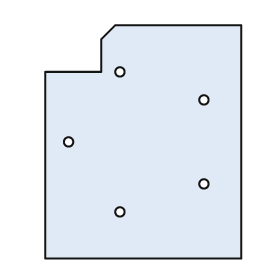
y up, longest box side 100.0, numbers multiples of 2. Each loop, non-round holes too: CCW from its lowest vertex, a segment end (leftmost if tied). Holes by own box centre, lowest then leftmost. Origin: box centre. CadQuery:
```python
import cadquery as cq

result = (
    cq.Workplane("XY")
    .moveTo(-42.0, -50.0)
    .lineTo(42.0, -50.0)
    .lineTo(42.0, 50.0)
    .lineTo(-12.0, 50.0)
    .lineTo(-18.0, 44.0)
    .lineTo(-18.0, 30.0)
    .lineTo(-42.0, 30.0)
    .close()
    .moveTo(-10.0, -30.0)
    .circle(2.0)
    .moveTo(26.0, -18.0)
    .circle(2.0)
    .moveTo(-32.0, 0.0)
    .circle(2.0)
    .moveTo(26.0, 18.0)
    .circle(2.0)
    .moveTo(-10.0, 30.0)
    .circle(2.0)
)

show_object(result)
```